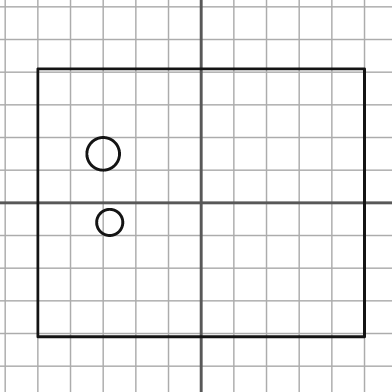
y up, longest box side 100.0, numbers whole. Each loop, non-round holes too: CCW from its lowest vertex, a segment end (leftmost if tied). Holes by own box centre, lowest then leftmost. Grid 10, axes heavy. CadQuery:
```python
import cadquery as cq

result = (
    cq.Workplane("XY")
    .moveTo(-50.0, -41.0)
    .lineTo(50.0, -41.0)
    .lineTo(50.0, 41.0)
    .lineTo(-50.0, 41.0)
    .close()
    .moveTo(-28.0, -6.0)
    .circle(4.0)
    .moveTo(-30.0, 15.0)
    .circle(5.0)
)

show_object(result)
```